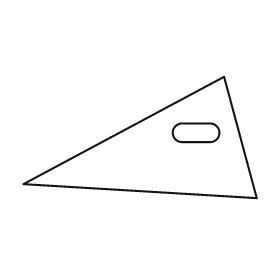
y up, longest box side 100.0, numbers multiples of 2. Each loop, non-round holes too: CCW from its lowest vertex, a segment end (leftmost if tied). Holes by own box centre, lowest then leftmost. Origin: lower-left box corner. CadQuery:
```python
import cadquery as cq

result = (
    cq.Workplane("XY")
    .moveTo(100.0, 0.0)
    .lineTo(86.0, 52.0)
    .lineTo(0.0, 6.0)
    .close()
    .moveTo(68.0, 24.0)
    .lineTo(80.0, 24.0)
    .threePointArc((84.0, 28.0), (80.0, 32.0))
    .lineTo(68.0, 32.0)
    .threePointArc((64.0, 28.0), (68.0, 24.0))
    .close()
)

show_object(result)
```